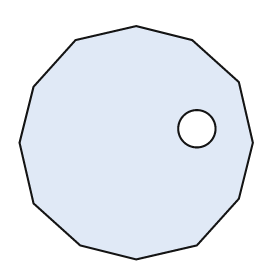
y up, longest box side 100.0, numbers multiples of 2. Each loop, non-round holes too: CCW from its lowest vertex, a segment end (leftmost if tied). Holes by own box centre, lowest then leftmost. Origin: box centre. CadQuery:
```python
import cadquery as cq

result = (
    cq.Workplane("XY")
    .moveTo(0.0, -50.0)
    .lineTo(26.0, -44.0)
    .lineTo(44.0, -24.0)
    .lineTo(50.0, 0.0)
    .lineTo(44.0, 26.0)
    .lineTo(24.0, 44.0)
    .lineTo(0.0, 50.0)
    .lineTo(-26.0, 44.0)
    .lineTo(-44.0, 24.0)
    .lineTo(-50.0, 0.0)
    .lineTo(-44.0, -26.0)
    .lineTo(-24.0, -44.0)
    .close()
    .moveTo(26.0, 6.0)
    .circle(8.0)
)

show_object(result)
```